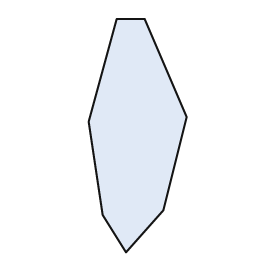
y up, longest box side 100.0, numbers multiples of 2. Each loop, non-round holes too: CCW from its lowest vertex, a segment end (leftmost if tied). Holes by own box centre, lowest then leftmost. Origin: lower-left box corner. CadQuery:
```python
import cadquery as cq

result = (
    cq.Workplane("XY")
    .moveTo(16.0, 0.0)
    .lineTo(32.0, 18.0)
    .lineTo(42.0, 58.0)
    .lineTo(24.0, 100.0)
    .lineTo(12.0, 100.0)
    .lineTo(0.0, 56.0)
    .lineTo(6.0, 16.0)
    .close()
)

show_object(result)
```